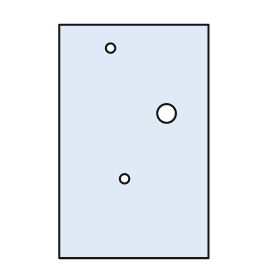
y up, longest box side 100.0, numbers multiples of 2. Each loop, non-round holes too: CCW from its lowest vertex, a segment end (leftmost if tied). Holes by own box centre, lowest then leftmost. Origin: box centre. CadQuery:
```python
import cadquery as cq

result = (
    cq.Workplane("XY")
    .moveTo(-32.0, -50.0)
    .lineTo(32.0, -50.0)
    .lineTo(32.0, 50.0)
    .lineTo(-32.0, 50.0)
    .close()
    .moveTo(-4.0, -16.0)
    .circle(2.0)
    .moveTo(14.0, 12.0)
    .circle(4.0)
    .moveTo(-10.0, 40.0)
    .circle(2.0)
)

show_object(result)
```